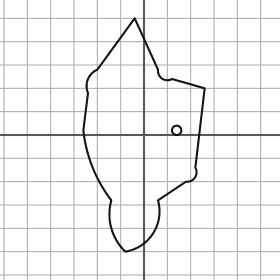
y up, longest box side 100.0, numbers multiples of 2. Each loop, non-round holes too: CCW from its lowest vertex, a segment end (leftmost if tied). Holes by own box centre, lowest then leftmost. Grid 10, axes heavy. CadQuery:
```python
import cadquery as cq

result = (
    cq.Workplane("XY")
    .moveTo(-8.0, -50.0)
    .threePointArc((4.0, -42.0), (6.0, -28.0))
    .lineTo(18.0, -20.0)
    .threePointArc((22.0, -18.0), (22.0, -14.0))
    .lineTo(26.0, 20.0)
    .lineTo(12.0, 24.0)
    .threePointArc((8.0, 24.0), (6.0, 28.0))
    .lineTo(-4.0, 50.0)
    .lineTo(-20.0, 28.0)
    .threePointArc((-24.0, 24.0), (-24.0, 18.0))
    .lineTo(-26.0, 2.0)
    .threePointArc((-22.0, -14.0), (-14.0, -28.0))
    .threePointArc((-14.0, -40.0), (-8.0, -50.0))
    .close()
    .moveTo(14.0, 2.0)
    .circle(2.0)
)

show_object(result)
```